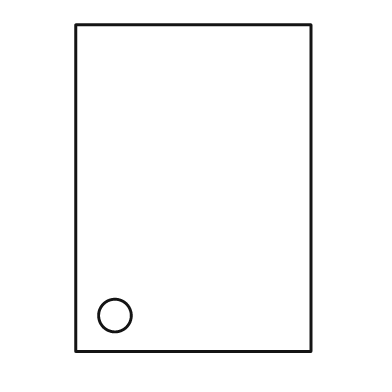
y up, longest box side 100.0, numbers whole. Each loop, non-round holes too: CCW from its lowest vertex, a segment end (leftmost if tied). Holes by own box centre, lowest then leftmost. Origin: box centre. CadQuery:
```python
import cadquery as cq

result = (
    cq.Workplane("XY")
    .moveTo(-36.0, -50.0)
    .lineTo(36.0, -50.0)
    .lineTo(36.0, 50.0)
    .lineTo(-36.0, 50.0)
    .close()
    .moveTo(-24.0, -39.0)
    .circle(5.0)
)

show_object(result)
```